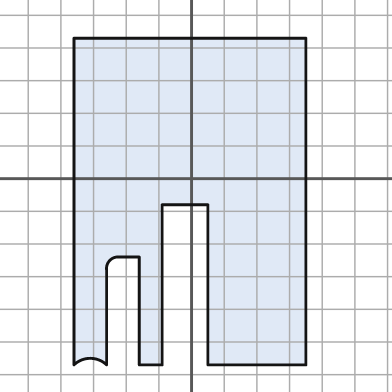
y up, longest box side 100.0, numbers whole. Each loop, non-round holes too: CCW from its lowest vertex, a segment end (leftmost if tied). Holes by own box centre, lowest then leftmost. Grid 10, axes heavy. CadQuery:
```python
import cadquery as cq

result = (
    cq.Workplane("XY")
    .moveTo(-36.0, -57.0)
    .threePointArc((-31.0, -55.0), (-26.0, -57.0))
    .lineTo(-26.0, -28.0)
    .threePointArc((-25.0, -25.0), (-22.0, -24.0))
    .lineTo(-16.0, -24.0)
    .lineTo(-16.0, -57.0)
    .lineTo(-9.0, -57.0)
    .lineTo(-9.0, -8.0)
    .lineTo(5.0, -8.0)
    .lineTo(5.0, -57.0)
    .lineTo(35.0, -57.0)
    .lineTo(35.0, 43.0)
    .lineTo(-36.0, 43.0)
    .close()
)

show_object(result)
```